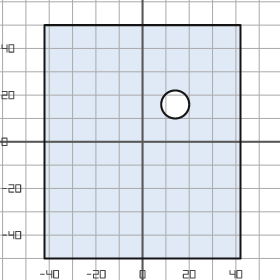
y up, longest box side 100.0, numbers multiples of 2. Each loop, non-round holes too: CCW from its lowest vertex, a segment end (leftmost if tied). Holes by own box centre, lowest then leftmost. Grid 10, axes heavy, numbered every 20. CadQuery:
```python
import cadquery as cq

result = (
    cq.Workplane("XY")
    .moveTo(-42.0, -50.0)
    .lineTo(42.0, -50.0)
    .lineTo(42.0, 50.0)
    .lineTo(-42.0, 50.0)
    .close()
    .moveTo(14.0, 16.0)
    .circle(6.0)
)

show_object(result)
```